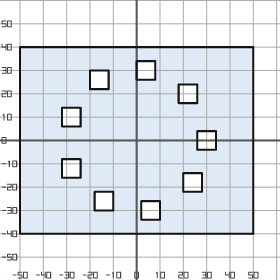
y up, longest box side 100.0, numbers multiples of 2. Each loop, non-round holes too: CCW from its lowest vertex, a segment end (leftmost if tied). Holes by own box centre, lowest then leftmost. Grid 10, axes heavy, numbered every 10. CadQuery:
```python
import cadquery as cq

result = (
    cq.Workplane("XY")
    .moveTo(-50.0, -40.0)
    .lineTo(50.0, -40.0)
    .lineTo(50.0, 40.0)
    .lineTo(-50.0, 40.0)
    .close()
    .moveTo(2.0, -34.0)
    .lineTo(10.0, -34.0)
    .lineTo(10.0, -26.0)
    .lineTo(2.0, -26.0)
    .close()
    .moveTo(-18.0, -30.0)
    .lineTo(-10.0, -30.0)
    .lineTo(-10.0, -22.0)
    .lineTo(-18.0, -22.0)
    .close()
    .moveTo(20.0, -22.0)
    .lineTo(28.0, -22.0)
    .lineTo(28.0, -14.0)
    .lineTo(20.0, -14.0)
    .close()
    .moveTo(-32.0, -16.0)
    .lineTo(-24.0, -16.0)
    .lineTo(-24.0, -8.0)
    .lineTo(-32.0, -8.0)
    .close()
    .moveTo(26.0, -4.0)
    .lineTo(34.0, -4.0)
    .lineTo(34.0, 4.0)
    .lineTo(26.0, 4.0)
    .close()
    .moveTo(-32.0, 6.0)
    .lineTo(-24.0, 6.0)
    .lineTo(-24.0, 14.0)
    .lineTo(-32.0, 14.0)
    .close()
    .moveTo(18.0, 16.0)
    .lineTo(26.0, 16.0)
    .lineTo(26.0, 24.0)
    .lineTo(18.0, 24.0)
    .close()
    .moveTo(-20.0, 22.0)
    .lineTo(-12.0, 22.0)
    .lineTo(-12.0, 30.0)
    .lineTo(-20.0, 30.0)
    .close()
    .moveTo(0.0, 26.0)
    .lineTo(8.0, 26.0)
    .lineTo(8.0, 34.0)
    .lineTo(0.0, 34.0)
    .close()
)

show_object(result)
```